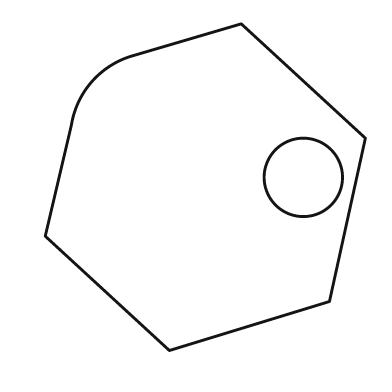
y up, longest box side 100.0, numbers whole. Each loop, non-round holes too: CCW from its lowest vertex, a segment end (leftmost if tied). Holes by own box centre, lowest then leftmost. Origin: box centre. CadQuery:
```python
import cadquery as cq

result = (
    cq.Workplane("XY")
    .moveTo(-11.0, -50.0)
    .lineTo(38.0, -35.0)
    .lineTo(49.0, 15.0)
    .lineTo(11.0, 50.0)
    .lineTo(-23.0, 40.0)
    .threePointArc((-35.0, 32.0), (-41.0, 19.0))
    .lineTo(-49.0, -15.0)
    .close()
    .moveTo(30.0, 3.0)
    .circle(12.0)
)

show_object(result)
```